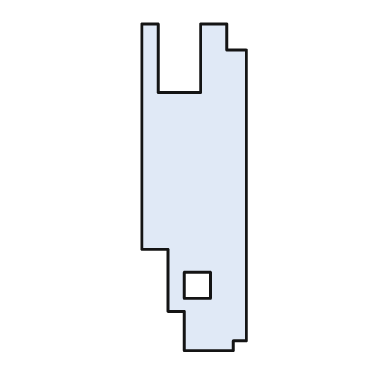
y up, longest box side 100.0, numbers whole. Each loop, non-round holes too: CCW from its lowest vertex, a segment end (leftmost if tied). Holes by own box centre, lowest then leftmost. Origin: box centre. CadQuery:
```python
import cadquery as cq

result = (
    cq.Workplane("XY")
    .moveTo(-3.0, -50.0)
    .lineTo(12.0, -50.0)
    .lineTo(12.0, -47.0)
    .lineTo(16.0, -47.0)
    .lineTo(16.0, 42.0)
    .lineTo(10.0, 42.0)
    .lineTo(10.0, 50.0)
    .lineTo(2.0, 50.0)
    .lineTo(2.0, 29.0)
    .lineTo(-11.0, 29.0)
    .lineTo(-11.0, 50.0)
    .lineTo(-16.0, 50.0)
    .lineTo(-16.0, -19.0)
    .lineTo(-8.0, -19.0)
    .lineTo(-8.0, -38.0)
    .lineTo(-3.0, -38.0)
    .close()
    .moveTo(-3.0, -34.0)
    .lineTo(5.0, -34.0)
    .lineTo(5.0, -26.0)
    .lineTo(-3.0, -26.0)
    .close()
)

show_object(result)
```